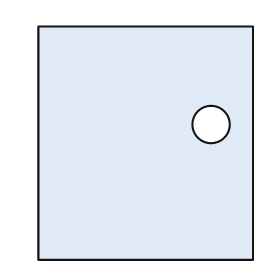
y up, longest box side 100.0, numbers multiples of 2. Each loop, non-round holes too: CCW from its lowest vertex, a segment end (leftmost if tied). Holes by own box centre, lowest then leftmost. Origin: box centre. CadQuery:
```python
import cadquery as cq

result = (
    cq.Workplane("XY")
    .moveTo(-46.0, -50.0)
    .lineTo(46.0, -50.0)
    .lineTo(46.0, 50.0)
    .lineTo(-46.0, 50.0)
    .close()
    .moveTo(28.0, 8.0)
    .circle(8.0)
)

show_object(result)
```